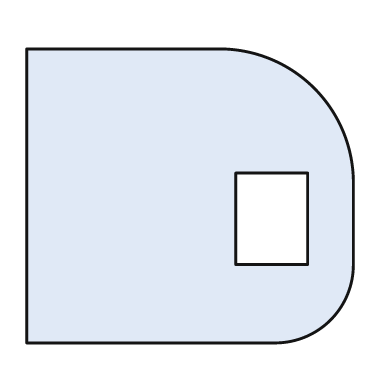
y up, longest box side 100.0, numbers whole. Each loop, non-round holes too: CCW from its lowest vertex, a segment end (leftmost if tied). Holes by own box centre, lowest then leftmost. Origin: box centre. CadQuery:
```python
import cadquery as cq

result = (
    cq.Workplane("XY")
    .moveTo(-50.0, -45.0)
    .lineTo(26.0, -45.0)
    .threePointArc((43.0, -38.0), (50.0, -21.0))
    .lineTo(50.0, 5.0)
    .threePointArc((38.0, 33.0), (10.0, 45.0))
    .lineTo(-50.0, 45.0)
    .close()
    .moveTo(14.0, -21.0)
    .lineTo(36.0, -21.0)
    .lineTo(36.0, 7.0)
    .lineTo(14.0, 7.0)
    .close()
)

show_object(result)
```